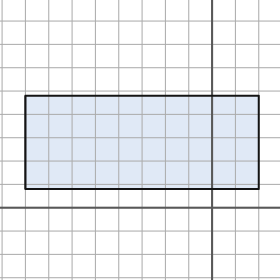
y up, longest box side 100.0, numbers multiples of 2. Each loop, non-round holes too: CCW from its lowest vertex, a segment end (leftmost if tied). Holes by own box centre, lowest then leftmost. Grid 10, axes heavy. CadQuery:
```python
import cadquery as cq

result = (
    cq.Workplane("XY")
    .moveTo(-80.0, 8.0)
    .lineTo(20.0, 8.0)
    .lineTo(20.0, 48.0)
    .lineTo(-80.0, 48.0)
    .close()
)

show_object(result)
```